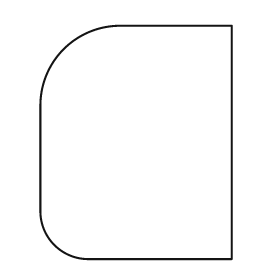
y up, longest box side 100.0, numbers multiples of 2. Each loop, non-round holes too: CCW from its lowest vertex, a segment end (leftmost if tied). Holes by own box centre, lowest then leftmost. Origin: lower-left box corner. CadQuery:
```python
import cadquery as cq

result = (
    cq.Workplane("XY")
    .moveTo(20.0, 0.0)
    .lineTo(82.0, 0.0)
    .lineTo(82.0, 100.0)
    .lineTo(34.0, 100.0)
    .threePointArc((10.0, 90.0), (0.0, 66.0))
    .lineTo(0.0, 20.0)
    .threePointArc((6.0, 6.0), (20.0, 0.0))
    .close()
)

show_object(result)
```